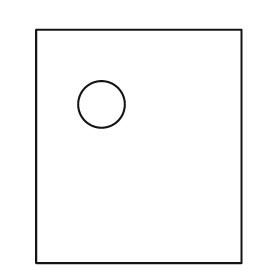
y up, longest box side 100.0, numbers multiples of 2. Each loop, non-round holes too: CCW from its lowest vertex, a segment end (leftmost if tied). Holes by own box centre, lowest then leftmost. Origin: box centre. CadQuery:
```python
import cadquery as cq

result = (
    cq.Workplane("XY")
    .moveTo(-44.0, -50.0)
    .lineTo(44.0, -50.0)
    .lineTo(44.0, 50.0)
    .lineTo(-44.0, 50.0)
    .close()
    .moveTo(-16.0, 18.0)
    .circle(10.0)
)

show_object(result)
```